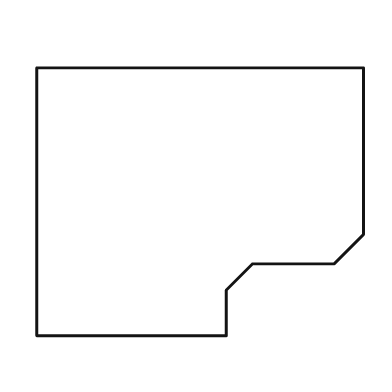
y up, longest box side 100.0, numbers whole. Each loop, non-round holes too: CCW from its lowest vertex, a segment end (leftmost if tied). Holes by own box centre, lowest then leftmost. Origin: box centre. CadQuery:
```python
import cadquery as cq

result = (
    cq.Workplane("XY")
    .moveTo(-50.0, -41.0)
    .lineTo(8.0, -41.0)
    .lineTo(8.0, -27.0)
    .lineTo(16.0, -19.0)
    .lineTo(41.0, -19.0)
    .lineTo(50.0, -10.0)
    .lineTo(50.0, 41.0)
    .lineTo(-50.0, 41.0)
    .close()
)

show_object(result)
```